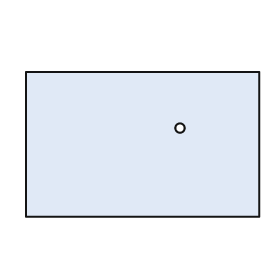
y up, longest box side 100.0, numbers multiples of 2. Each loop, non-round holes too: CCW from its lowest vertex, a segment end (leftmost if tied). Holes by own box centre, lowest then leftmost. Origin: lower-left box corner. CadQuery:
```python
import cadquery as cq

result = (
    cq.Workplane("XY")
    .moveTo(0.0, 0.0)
    .lineTo(100.0, 0.0)
    .lineTo(100.0, 62.0)
    .lineTo(0.0, 62.0)
    .close()
    .moveTo(66.0, 38.0)
    .circle(2.0)
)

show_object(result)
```